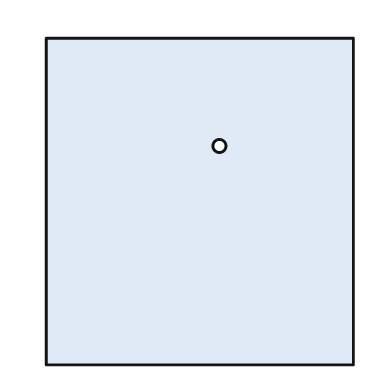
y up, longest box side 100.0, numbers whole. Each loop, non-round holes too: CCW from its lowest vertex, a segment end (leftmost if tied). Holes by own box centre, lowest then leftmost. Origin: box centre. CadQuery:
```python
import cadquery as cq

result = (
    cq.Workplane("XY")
    .moveTo(-47.0, -50.0)
    .lineTo(47.0, -50.0)
    .lineTo(47.0, 50.0)
    .lineTo(-47.0, 50.0)
    .close()
    .moveTo(6.0, 17.0)
    .circle(2.0)
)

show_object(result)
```